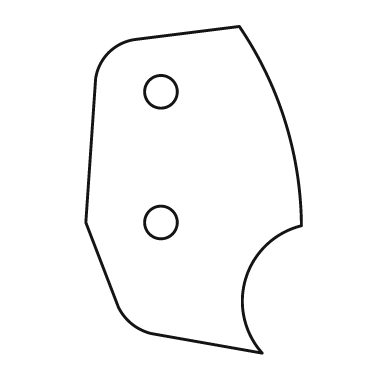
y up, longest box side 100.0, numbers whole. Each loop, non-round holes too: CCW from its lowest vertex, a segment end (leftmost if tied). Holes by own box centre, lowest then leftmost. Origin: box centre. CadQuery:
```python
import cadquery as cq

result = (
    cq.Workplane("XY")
    .moveTo(21.0, -50.0)
    .threePointArc((16.0, -27.0), (33.0, -11.0))
    .threePointArc((28.0, 21.0), (14.0, 50.0))
    .lineTo(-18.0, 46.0)
    .threePointArc((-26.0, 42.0), (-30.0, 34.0))
    .lineTo(-33.0, -10.0)
    .lineTo(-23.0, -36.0)
    .threePointArc((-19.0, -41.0), (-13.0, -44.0))
    .close()
    .moveTo(-10.0, -10.0)
    .circle(5.0)
    .moveTo(-10.0, 30.0)
    .circle(5.0)
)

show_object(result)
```